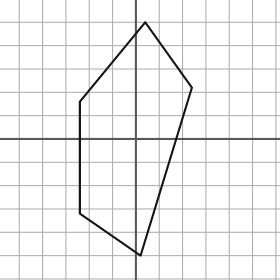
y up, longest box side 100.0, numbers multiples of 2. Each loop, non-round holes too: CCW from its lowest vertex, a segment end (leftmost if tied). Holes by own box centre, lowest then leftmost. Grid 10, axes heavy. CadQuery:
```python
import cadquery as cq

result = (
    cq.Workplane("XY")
    .moveTo(2.0, -50.0)
    .lineTo(24.0, 22.0)
    .lineTo(4.0, 50.0)
    .lineTo(-24.0, 16.0)
    .lineTo(-24.0, -32.0)
    .close()
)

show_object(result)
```